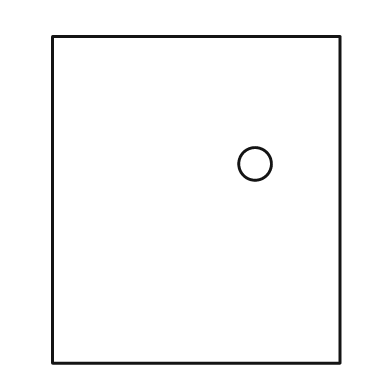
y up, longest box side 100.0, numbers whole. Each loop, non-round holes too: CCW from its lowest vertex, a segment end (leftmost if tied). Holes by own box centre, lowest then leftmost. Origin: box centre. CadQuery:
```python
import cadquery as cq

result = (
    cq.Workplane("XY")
    .moveTo(-44.0, -50.0)
    .lineTo(44.0, -50.0)
    .lineTo(44.0, 50.0)
    .lineTo(-44.0, 50.0)
    .close()
    .moveTo(18.0, 11.0)
    .circle(5.0)
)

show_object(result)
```